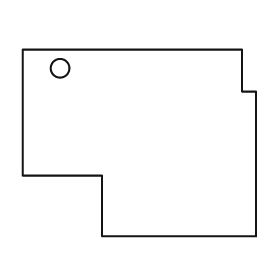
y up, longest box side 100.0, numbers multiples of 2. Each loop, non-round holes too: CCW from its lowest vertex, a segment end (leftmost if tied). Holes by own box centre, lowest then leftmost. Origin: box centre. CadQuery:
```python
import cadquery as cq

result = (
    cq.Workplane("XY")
    .moveTo(-16.0, -40.0)
    .lineTo(50.0, -40.0)
    .lineTo(50.0, 22.0)
    .lineTo(44.0, 22.0)
    .lineTo(44.0, 40.0)
    .lineTo(-50.0, 40.0)
    .lineTo(-50.0, -14.0)
    .lineTo(-16.0, -14.0)
    .close()
    .moveTo(-34.0, 32.0)
    .circle(4.0)
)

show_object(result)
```